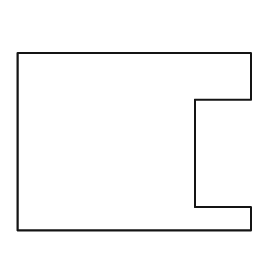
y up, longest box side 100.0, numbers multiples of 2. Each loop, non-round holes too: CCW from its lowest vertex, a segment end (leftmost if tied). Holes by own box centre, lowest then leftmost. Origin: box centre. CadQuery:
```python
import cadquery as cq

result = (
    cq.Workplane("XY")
    .moveTo(-50.0, -38.0)
    .lineTo(50.0, -38.0)
    .lineTo(50.0, -28.0)
    .lineTo(26.0, -28.0)
    .lineTo(26.0, 18.0)
    .lineTo(50.0, 18.0)
    .lineTo(50.0, 38.0)
    .lineTo(-50.0, 38.0)
    .close()
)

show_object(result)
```